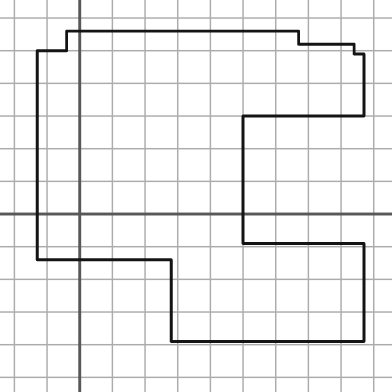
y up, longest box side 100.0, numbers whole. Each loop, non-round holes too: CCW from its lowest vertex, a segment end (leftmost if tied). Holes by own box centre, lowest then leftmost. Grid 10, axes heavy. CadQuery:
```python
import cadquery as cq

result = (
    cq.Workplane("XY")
    .moveTo(28.0, -39.0)
    .lineTo(87.0, -39.0)
    .lineTo(87.0, -9.0)
    .lineTo(50.0, -9.0)
    .lineTo(50.0, 30.0)
    .lineTo(87.0, 30.0)
    .lineTo(87.0, 49.0)
    .lineTo(84.0, 49.0)
    .lineTo(84.0, 52.0)
    .lineTo(67.0, 52.0)
    .lineTo(67.0, 56.0)
    .lineTo(-4.0, 56.0)
    .lineTo(-4.0, 50.0)
    .lineTo(-13.0, 50.0)
    .lineTo(-13.0, -14.0)
    .lineTo(28.0, -14.0)
    .close()
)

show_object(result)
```